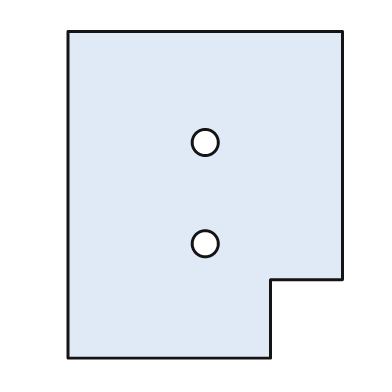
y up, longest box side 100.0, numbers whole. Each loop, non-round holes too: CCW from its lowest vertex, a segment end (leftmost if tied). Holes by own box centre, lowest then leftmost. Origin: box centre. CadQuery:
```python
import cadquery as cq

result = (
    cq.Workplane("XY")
    .moveTo(-42.0, -50.0)
    .lineTo(20.0, -50.0)
    .lineTo(20.0, -26.0)
    .lineTo(42.0, -26.0)
    .lineTo(42.0, 50.0)
    .lineTo(-42.0, 50.0)
    .close()
    .moveTo(0.0, -15.0)
    .circle(4.0)
    .moveTo(0.0, 16.0)
    .circle(4.0)
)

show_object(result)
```